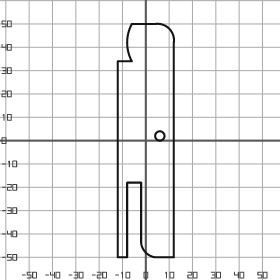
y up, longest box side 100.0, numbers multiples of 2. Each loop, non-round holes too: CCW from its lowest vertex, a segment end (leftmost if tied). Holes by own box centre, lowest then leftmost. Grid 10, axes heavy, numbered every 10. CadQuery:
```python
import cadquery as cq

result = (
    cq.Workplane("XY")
    .moveTo(-12.0, -50.0)
    .lineTo(-8.0, -50.0)
    .lineTo(-8.0, -18.0)
    .lineTo(-2.0, -18.0)
    .lineTo(-2.0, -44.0)
    .threePointArc((0.0, -48.0), (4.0, -50.0))
    .lineTo(12.0, -50.0)
    .lineTo(12.0, 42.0)
    .threePointArc((10.0, 48.0), (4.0, 50.0))
    .lineTo(-6.0, 50.0)
    .threePointArc((-8.0, 42.0), (-6.0, 34.0))
    .lineTo(-12.0, 34.0)
    .close()
    .moveTo(6.0, 2.0)
    .circle(2.0)
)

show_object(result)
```